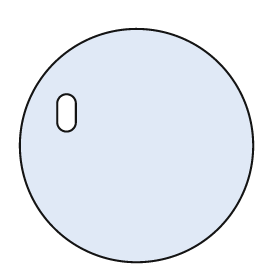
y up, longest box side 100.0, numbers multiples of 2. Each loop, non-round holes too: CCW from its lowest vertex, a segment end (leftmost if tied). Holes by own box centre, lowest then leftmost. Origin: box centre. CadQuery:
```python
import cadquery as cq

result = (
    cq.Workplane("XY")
    .moveTo(0.0, 0.0)
    .circle(50.0)
    .moveTo(-34.0, 10.0)
    .threePointArc((-30.0, 6.0), (-26.0, 10.0))
    .lineTo(-26.0, 18.0)
    .threePointArc((-30.0, 22.0), (-34.0, 18.0))
    .close()
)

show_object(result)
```